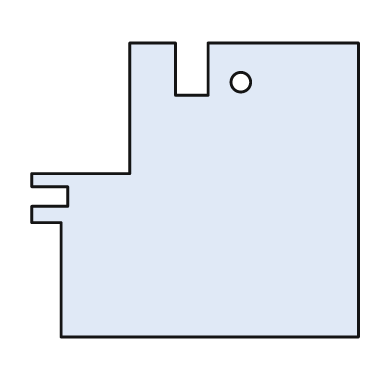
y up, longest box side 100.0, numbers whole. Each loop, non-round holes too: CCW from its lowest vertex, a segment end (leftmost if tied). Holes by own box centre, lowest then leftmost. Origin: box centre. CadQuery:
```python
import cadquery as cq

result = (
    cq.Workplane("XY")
    .moveTo(-41.0, -45.0)
    .lineTo(50.0, -45.0)
    .lineTo(50.0, 45.0)
    .lineTo(4.0, 45.0)
    .lineTo(4.0, 29.0)
    .lineTo(-6.0, 29.0)
    .lineTo(-6.0, 45.0)
    .lineTo(-20.0, 45.0)
    .lineTo(-20.0, 5.0)
    .lineTo(-50.0, 5.0)
    .lineTo(-50.0, 1.0)
    .lineTo(-39.0, 1.0)
    .lineTo(-39.0, -5.0)
    .lineTo(-50.0, -5.0)
    .lineTo(-50.0, -10.0)
    .lineTo(-41.0, -10.0)
    .close()
    .moveTo(14.0, 33.0)
    .circle(3.0)
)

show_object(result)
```